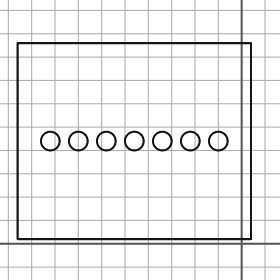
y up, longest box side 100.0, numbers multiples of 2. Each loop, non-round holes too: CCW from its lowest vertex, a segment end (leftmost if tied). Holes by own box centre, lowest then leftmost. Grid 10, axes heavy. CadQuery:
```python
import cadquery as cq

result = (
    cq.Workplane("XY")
    .moveTo(-96.0, 2.0)
    .lineTo(4.0, 2.0)
    .lineTo(4.0, 86.0)
    .lineTo(-96.0, 86.0)
    .close()
    .moveTo(-82.0, 44.0)
    .circle(4.0)
    .moveTo(-70.0, 44.0)
    .circle(4.0)
    .moveTo(-58.0, 44.0)
    .circle(4.0)
    .moveTo(-46.0, 44.0)
    .circle(4.0)
    .moveTo(-34.0, 44.0)
    .circle(4.0)
    .moveTo(-22.0, 44.0)
    .circle(4.0)
    .moveTo(-10.0, 44.0)
    .circle(4.0)
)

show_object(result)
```